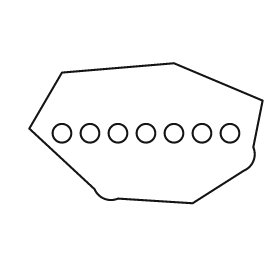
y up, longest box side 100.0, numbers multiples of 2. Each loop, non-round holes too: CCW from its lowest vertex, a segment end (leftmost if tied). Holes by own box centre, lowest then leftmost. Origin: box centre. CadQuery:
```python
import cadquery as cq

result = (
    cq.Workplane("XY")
    .moveTo(20.0, -30.0)
    .lineTo(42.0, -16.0)
    .threePointArc((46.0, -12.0), (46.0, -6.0))
    .lineTo(50.0, 14.0)
    .lineTo(12.0, 30.0)
    .lineTo(-36.0, 26.0)
    .lineTo(-50.0, 2.0)
    .lineTo(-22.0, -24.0)
    .threePointArc((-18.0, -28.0), (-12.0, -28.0))
    .close()
    .moveTo(-36.0, 0.0)
    .circle(4.0)
    .moveTo(-24.0, 0.0)
    .circle(4.0)
    .moveTo(-12.0, 0.0)
    .circle(4.0)
    .moveTo(0.0, 0.0)
    .circle(4.0)
    .moveTo(12.0, 0.0)
    .circle(4.0)
    .moveTo(24.0, 0.0)
    .circle(4.0)
    .moveTo(36.0, 0.0)
    .circle(4.0)
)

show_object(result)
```